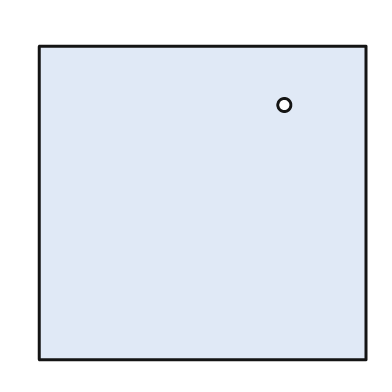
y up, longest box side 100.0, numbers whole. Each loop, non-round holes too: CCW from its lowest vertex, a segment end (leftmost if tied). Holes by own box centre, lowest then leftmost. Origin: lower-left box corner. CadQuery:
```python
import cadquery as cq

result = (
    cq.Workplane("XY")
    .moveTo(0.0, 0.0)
    .lineTo(100.0, 0.0)
    .lineTo(100.0, 96.0)
    .lineTo(0.0, 96.0)
    .close()
    .moveTo(75.0, 78.0)
    .circle(2.0)
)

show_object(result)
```